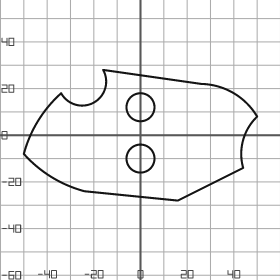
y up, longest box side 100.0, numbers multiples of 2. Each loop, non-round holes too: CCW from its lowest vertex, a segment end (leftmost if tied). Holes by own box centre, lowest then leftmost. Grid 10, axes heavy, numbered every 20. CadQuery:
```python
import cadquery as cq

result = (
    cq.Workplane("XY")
    .moveTo(16.0, -28.0)
    .lineTo(44.0, -14.0)
    .threePointArc((44.0, -2.0), (50.0, 8.0))
    .threePointArc((40.0, 18.0), (26.0, 22.0))
    .lineTo(-16.0, 28.0)
    .threePointArc((-20.0, 14.0), (-34.0, 18.0))
    .threePointArc((-44.0, 6.0), (-50.0, -8.0))
    .threePointArc((-38.0, -18.0), (-24.0, -24.0))
    .close()
    .moveTo(0.0, -10.0)
    .circle(6.0)
    .moveTo(0.0, 12.0)
    .circle(6.0)
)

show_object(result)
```